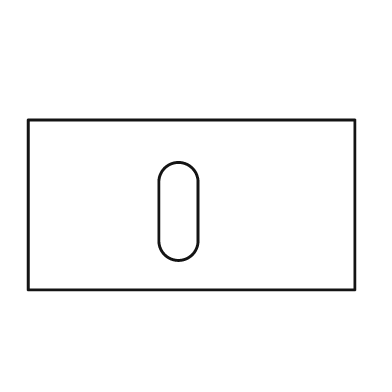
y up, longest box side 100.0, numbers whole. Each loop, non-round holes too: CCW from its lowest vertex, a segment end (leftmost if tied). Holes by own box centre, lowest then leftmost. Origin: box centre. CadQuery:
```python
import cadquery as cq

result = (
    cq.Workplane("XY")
    .moveTo(-50.0, -26.0)
    .lineTo(50.0, -26.0)
    .lineTo(50.0, 26.0)
    .lineTo(-50.0, 26.0)
    .close()
    .moveTo(-10.0, -11.0)
    .threePointArc((-4.0, -17.0), (2.0, -11.0))
    .lineTo(2.0, 7.0)
    .threePointArc((-4.0, 13.0), (-10.0, 7.0))
    .close()
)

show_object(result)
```